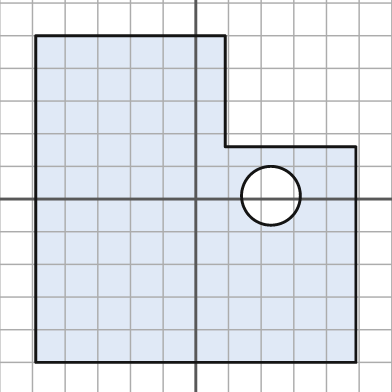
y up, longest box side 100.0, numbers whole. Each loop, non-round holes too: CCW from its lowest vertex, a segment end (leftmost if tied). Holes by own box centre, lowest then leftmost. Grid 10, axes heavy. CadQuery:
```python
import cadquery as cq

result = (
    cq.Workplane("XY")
    .moveTo(-49.0, -50.0)
    .lineTo(49.0, -50.0)
    .lineTo(49.0, 16.0)
    .lineTo(9.0, 16.0)
    .lineTo(9.0, 50.0)
    .lineTo(-49.0, 50.0)
    .close()
    .moveTo(23.0, 1.0)
    .circle(9.0)
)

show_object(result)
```